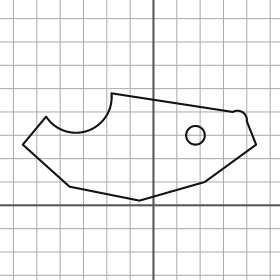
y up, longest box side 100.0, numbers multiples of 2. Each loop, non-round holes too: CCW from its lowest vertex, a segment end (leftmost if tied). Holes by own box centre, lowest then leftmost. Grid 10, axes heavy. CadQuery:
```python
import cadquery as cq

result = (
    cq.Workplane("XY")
    .moveTo(-6.0, 2.0)
    .lineTo(22.0, 10.0)
    .lineTo(44.0, 26.0)
    .lineTo(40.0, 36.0)
    .threePointArc((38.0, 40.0), (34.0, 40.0))
    .lineTo(-18.0, 48.0)
    .threePointArc((-28.0, 32.0), (-46.0, 38.0))
    .lineTo(-56.0, 26.0)
    .lineTo(-36.0, 8.0)
    .close()
    .moveTo(18.0, 30.0)
    .circle(4.0)
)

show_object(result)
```